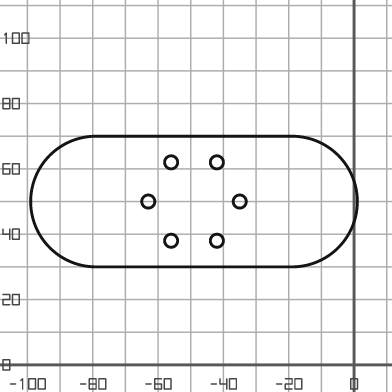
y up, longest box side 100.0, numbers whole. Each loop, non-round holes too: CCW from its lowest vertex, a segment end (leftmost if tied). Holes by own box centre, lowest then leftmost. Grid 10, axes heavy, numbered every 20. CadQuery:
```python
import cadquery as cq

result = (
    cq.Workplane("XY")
    .moveTo(-79.0, 30.0)
    .lineTo(-19.0, 30.0)
    .threePointArc((1.0, 50.0), (-19.0, 70.0))
    .lineTo(-79.0, 70.0)
    .threePointArc((-99.0, 50.0), (-79.0, 30.0))
    .close()
    .moveTo(-56.0, 38.0)
    .circle(2.0)
    .moveTo(-42.0, 38.0)
    .circle(2.0)
    .moveTo(-63.0, 50.0)
    .circle(2.0)
    .moveTo(-35.0, 50.0)
    .circle(2.0)
    .moveTo(-56.0, 62.0)
    .circle(2.0)
    .moveTo(-42.0, 62.0)
    .circle(2.0)
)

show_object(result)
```